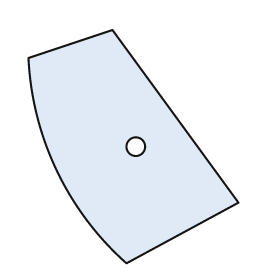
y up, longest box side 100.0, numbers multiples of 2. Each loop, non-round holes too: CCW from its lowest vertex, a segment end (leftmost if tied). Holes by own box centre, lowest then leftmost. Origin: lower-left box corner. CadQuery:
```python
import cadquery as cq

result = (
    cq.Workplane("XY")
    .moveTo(42.0, 0.0)
    .lineTo(90.0, 26.0)
    .lineTo(36.0, 100.0)
    .lineTo(0.0, 88.0)
    .threePointArc((12.0, 40.0), (42.0, 0.0))
    .close()
    .moveTo(46.0, 50.0)
    .circle(4.0)
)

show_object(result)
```